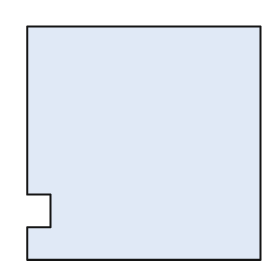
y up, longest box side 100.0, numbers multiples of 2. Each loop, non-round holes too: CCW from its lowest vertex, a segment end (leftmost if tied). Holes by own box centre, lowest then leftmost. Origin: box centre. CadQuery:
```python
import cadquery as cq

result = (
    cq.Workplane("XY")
    .moveTo(-50.0, -50.0)
    .lineTo(50.0, -50.0)
    .lineTo(50.0, 50.0)
    .lineTo(-50.0, 50.0)
    .lineTo(-50.0, -22.0)
    .lineTo(-40.0, -22.0)
    .lineTo(-40.0, -36.0)
    .lineTo(-50.0, -36.0)
    .close()
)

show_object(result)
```